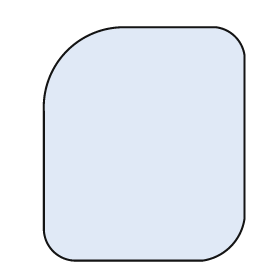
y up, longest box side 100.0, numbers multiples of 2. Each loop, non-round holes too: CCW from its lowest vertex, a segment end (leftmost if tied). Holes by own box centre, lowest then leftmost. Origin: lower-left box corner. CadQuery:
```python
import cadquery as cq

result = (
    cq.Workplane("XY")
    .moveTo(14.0, 0.0)
    .lineTo(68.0, 0.0)
    .threePointArc((80.0, 6.0), (86.0, 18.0))
    .lineTo(86.0, 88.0)
    .threePointArc((82.0, 96.0), (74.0, 100.0))
    .lineTo(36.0, 100.0)
    .threePointArc((10.0, 90.0), (0.0, 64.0))
    .lineTo(0.0, 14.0)
    .threePointArc((4.0, 4.0), (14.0, 0.0))
    .close()
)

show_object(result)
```